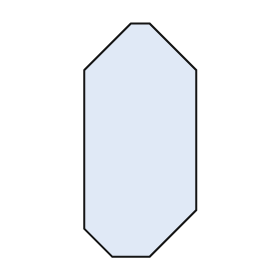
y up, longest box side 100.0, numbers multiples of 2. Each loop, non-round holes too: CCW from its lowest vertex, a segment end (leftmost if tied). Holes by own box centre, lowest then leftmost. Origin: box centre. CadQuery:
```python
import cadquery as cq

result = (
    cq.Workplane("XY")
    .moveTo(-12.0, -50.0)
    .lineTo(4.0, -50.0)
    .lineTo(24.0, -30.0)
    .lineTo(24.0, 30.0)
    .lineTo(4.0, 50.0)
    .lineTo(-4.0, 50.0)
    .lineTo(-24.0, 30.0)
    .lineTo(-24.0, -38.0)
    .close()
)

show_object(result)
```